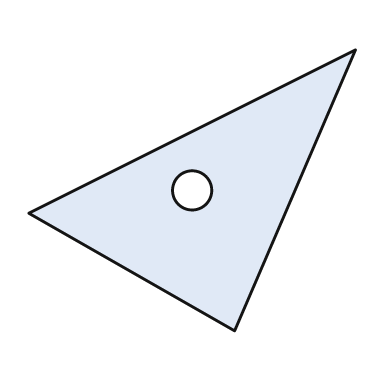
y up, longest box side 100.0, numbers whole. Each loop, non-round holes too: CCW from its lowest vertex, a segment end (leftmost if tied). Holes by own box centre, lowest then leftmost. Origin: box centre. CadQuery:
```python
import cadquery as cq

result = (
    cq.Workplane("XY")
    .moveTo(13.0, -43.0)
    .lineTo(50.0, 43.0)
    .lineTo(-50.0, -7.0)
    .close()
    .moveTo(0.0, 0.0)
    .circle(6.0)
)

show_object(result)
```